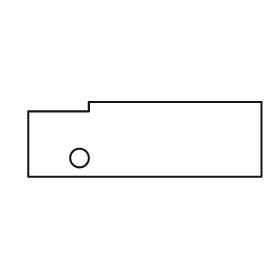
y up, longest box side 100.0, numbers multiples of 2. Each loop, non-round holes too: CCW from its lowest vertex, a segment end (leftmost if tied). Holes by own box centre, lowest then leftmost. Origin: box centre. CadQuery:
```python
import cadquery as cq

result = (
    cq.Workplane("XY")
    .moveTo(-50.0, -16.0)
    .lineTo(50.0, -16.0)
    .lineTo(50.0, 16.0)
    .lineTo(-24.0, 16.0)
    .lineTo(-24.0, 12.0)
    .lineTo(-50.0, 12.0)
    .close()
    .moveTo(-28.0, -8.0)
    .circle(4.0)
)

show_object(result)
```